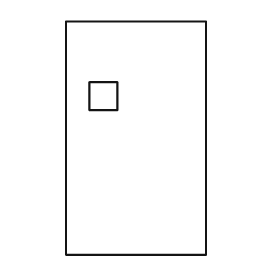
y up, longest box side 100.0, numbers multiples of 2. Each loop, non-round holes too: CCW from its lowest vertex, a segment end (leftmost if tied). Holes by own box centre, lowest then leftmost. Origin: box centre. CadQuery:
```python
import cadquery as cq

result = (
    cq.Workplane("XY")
    .moveTo(-30.0, -50.0)
    .lineTo(30.0, -50.0)
    .lineTo(30.0, 50.0)
    .lineTo(-30.0, 50.0)
    .close()
    .moveTo(-20.0, 12.0)
    .lineTo(-8.0, 12.0)
    .lineTo(-8.0, 24.0)
    .lineTo(-20.0, 24.0)
    .close()
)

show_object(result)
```